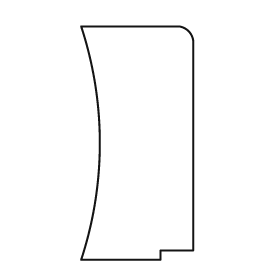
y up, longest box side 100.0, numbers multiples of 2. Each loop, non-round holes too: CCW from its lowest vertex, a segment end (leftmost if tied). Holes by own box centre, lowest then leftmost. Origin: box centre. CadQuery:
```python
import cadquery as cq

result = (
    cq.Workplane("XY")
    .moveTo(-24.0, -50.0)
    .lineTo(10.0, -50.0)
    .lineTo(10.0, -46.0)
    .lineTo(24.0, -46.0)
    .lineTo(24.0, 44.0)
    .threePointArc((22.0, 48.0), (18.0, 50.0))
    .lineTo(-24.0, 50.0)
    .threePointArc((-16.0, 0.0), (-24.0, -50.0))
    .close()
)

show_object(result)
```